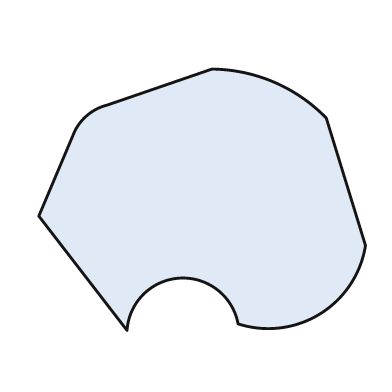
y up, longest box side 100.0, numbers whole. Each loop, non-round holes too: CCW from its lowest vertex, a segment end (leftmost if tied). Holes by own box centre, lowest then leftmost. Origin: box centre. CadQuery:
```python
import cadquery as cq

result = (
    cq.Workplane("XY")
    .moveTo(-23.0, -40.0)
    .threePointArc((-7.0, -24.0), (11.0, -38.0))
    .threePointArc((36.0, -35.0), (50.0, -14.0))
    .lineTo(38.0, 25.0)
    .threePointArc((22.0, 36.0), (3.0, 40.0))
    .lineTo(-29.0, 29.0)
    .threePointArc((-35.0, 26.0), (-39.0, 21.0))
    .lineTo(-50.0, -5.0)
    .close()
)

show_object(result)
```